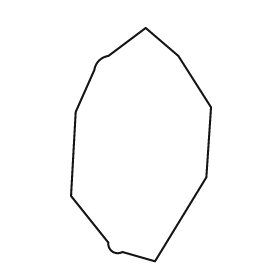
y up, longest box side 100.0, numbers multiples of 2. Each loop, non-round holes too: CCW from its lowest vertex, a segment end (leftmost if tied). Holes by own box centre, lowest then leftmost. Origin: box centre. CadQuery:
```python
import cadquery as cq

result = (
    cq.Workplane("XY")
    .moveTo(6.0, -50.0)
    .lineTo(28.0, -14.0)
    .lineTo(30.0, 16.0)
    .lineTo(16.0, 38.0)
    .lineTo(2.0, 50.0)
    .lineTo(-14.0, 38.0)
    .threePointArc((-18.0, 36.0), (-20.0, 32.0))
    .lineTo(-28.0, 14.0)
    .lineTo(-30.0, -22.0)
    .lineTo(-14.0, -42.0)
    .threePointArc((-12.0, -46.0), (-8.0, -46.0))
    .close()
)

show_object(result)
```